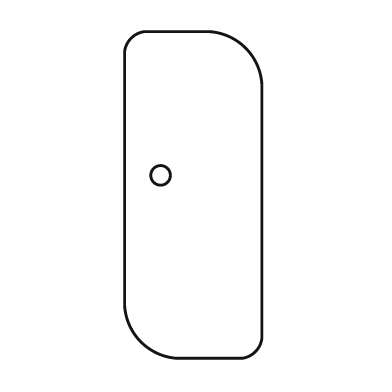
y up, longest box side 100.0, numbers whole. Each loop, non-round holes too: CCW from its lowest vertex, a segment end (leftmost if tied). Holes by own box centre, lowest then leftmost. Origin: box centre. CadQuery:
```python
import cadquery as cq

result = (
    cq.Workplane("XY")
    .moveTo(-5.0, -50.0)
    .lineTo(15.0, -50.0)
    .threePointArc((19.0, -48.0), (21.0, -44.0))
    .lineTo(21.0, 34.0)
    .threePointArc((16.0, 45.0), (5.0, 50.0))
    .lineTo(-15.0, 50.0)
    .threePointArc((-19.0, 48.0), (-21.0, 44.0))
    .lineTo(-21.0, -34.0)
    .threePointArc((-16.0, -45.0), (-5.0, -50.0))
    .close()
    .moveTo(-10.0, 6.0)
    .circle(3.0)
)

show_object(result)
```